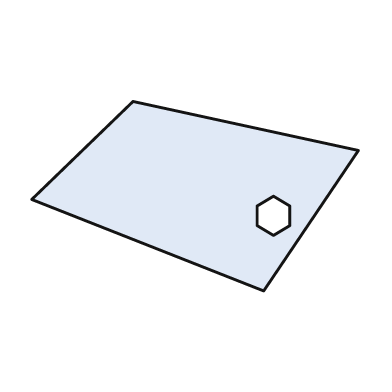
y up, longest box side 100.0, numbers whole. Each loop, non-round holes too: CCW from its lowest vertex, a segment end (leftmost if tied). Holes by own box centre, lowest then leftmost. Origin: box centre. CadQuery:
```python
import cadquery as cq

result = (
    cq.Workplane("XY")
    .moveTo(21.0, -29.0)
    .lineTo(50.0, 14.0)
    .lineTo(-19.0, 29.0)
    .lineTo(-50.0, -1.0)
    .close()
    .moveTo(24.0, -12.0)
    .lineTo(29.0, -9.0)
    .lineTo(29.0, -3.0)
    .lineTo(24.0, 0.0)
    .lineTo(19.0, -3.0)
    .lineTo(19.0, -9.0)
    .close()
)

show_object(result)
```